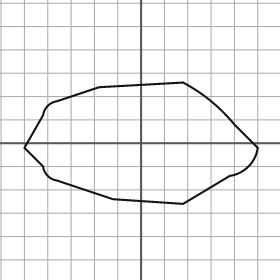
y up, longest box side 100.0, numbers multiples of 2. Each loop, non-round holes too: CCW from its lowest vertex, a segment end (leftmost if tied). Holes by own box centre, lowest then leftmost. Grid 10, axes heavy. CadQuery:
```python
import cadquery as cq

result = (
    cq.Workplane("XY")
    .moveTo(18.0, -26.0)
    .lineTo(38.0, -14.0)
    .threePointArc((46.0, -10.0), (50.0, -2.0))
    .lineTo(40.0, 8.0)
    .threePointArc((30.0, 18.0), (18.0, 26.0))
    .lineTo(-18.0, 24.0)
    .lineTo(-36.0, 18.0)
    .threePointArc((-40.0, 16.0), (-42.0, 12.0))
    .lineTo(-50.0, -2.0)
    .lineTo(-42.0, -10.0)
    .threePointArc((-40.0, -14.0), (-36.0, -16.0))
    .lineTo(-12.0, -24.0)
    .close()
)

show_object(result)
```